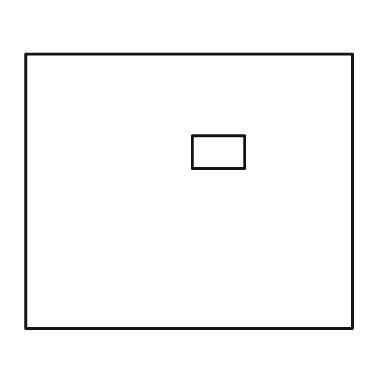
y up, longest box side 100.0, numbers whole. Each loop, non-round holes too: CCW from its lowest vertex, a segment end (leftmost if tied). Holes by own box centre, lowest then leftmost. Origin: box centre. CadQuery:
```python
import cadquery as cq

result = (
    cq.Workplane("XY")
    .moveTo(-50.0, -42.0)
    .lineTo(50.0, -42.0)
    .lineTo(50.0, 42.0)
    .lineTo(-50.0, 42.0)
    .close()
    .moveTo(1.0, 7.0)
    .lineTo(17.0, 7.0)
    .lineTo(17.0, 17.0)
    .lineTo(1.0, 17.0)
    .close()
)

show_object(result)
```